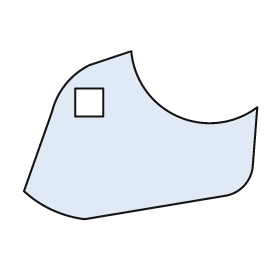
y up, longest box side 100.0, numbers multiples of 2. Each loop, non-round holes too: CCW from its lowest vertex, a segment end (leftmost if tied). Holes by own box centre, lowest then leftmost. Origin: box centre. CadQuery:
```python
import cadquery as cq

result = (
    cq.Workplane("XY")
    .moveTo(-24.0, -36.0)
    .lineTo(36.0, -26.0)
    .threePointArc((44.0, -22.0), (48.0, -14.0))
    .lineTo(50.0, 12.0)
    .threePointArc((16.0, 8.0), (-4.0, 36.0))
    .lineTo(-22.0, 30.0)
    .threePointArc((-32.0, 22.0), (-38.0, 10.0))
    .lineTo(-50.0, -24.0)
    .threePointArc((-38.0, -32.0), (-24.0, -36.0))
    .close()
    .moveTo(-28.0, 8.0)
    .lineTo(-16.0, 8.0)
    .lineTo(-16.0, 20.0)
    .lineTo(-28.0, 20.0)
    .close()
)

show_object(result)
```